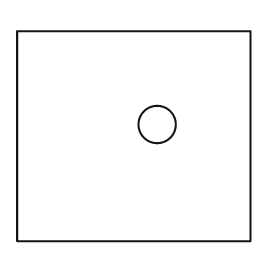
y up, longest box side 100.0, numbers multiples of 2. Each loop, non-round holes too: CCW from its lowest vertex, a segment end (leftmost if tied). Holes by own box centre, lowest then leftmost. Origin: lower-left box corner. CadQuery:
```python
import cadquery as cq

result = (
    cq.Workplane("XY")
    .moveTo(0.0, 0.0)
    .lineTo(100.0, 0.0)
    .lineTo(100.0, 90.0)
    .lineTo(0.0, 90.0)
    .close()
    .moveTo(60.0, 50.0)
    .circle(8.0)
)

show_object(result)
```